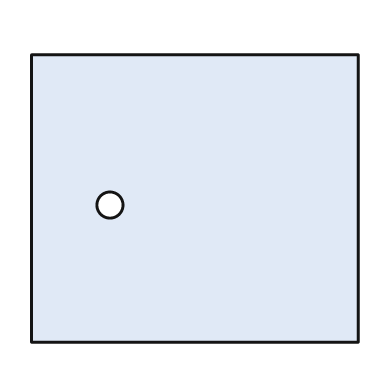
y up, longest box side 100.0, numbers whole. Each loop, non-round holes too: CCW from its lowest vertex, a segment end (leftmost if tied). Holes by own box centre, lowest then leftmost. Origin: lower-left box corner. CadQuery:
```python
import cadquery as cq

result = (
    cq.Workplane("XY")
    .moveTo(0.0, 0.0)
    .lineTo(100.0, 0.0)
    .lineTo(100.0, 88.0)
    .lineTo(0.0, 88.0)
    .close()
    .moveTo(24.0, 42.0)
    .circle(4.0)
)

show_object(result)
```